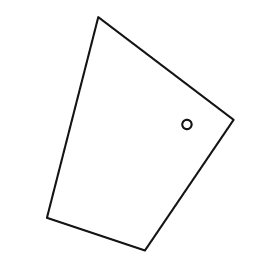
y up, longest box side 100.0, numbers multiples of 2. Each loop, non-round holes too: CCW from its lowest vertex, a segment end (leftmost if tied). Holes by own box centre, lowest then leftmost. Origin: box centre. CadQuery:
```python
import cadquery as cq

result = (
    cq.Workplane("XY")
    .moveTo(2.0, -50.0)
    .lineTo(40.0, 6.0)
    .lineTo(-18.0, 50.0)
    .lineTo(-40.0, -36.0)
    .close()
    .moveTo(20.0, 4.0)
    .circle(2.0)
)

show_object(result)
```